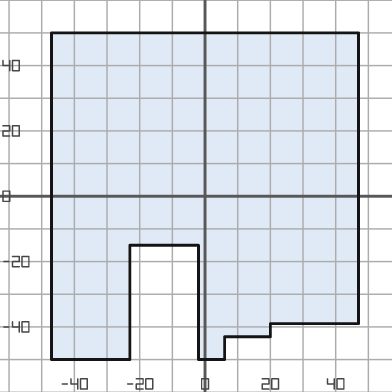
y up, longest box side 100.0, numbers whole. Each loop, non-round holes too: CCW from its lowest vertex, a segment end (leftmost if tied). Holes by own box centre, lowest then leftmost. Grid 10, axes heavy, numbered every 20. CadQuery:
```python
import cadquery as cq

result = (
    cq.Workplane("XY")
    .moveTo(-47.0, -50.0)
    .lineTo(-23.0, -50.0)
    .lineTo(-23.0, -15.0)
    .lineTo(-2.0, -15.0)
    .lineTo(-2.0, -50.0)
    .lineTo(6.0, -50.0)
    .lineTo(6.0, -43.0)
    .lineTo(20.0, -43.0)
    .lineTo(20.0, -39.0)
    .lineTo(47.0, -39.0)
    .lineTo(47.0, 50.0)
    .lineTo(-47.0, 50.0)
    .close()
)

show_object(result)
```